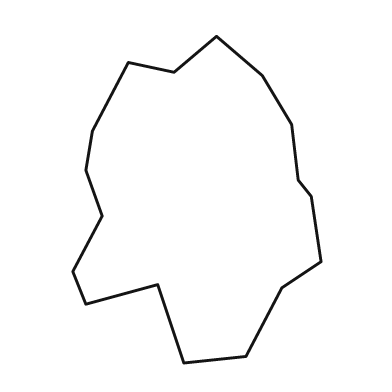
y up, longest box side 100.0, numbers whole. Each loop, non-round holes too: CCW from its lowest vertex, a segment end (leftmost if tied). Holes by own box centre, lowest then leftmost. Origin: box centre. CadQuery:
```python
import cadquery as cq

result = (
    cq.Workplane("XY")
    .moveTo(-4.0, -50.0)
    .lineTo(15.0, -48.0)
    .lineTo(26.0, -27.0)
    .lineTo(38.0, -19.0)
    .lineTo(35.0, 1.0)
    .lineTo(31.0, 6.0)
    .lineTo(29.0, 23.0)
    .lineTo(20.0, 38.0)
    .lineTo(6.0, 50.0)
    .lineTo(-7.0, 39.0)
    .lineTo(-21.0, 42.0)
    .lineTo(-32.0, 21.0)
    .lineTo(-34.0, 9.0)
    .lineTo(-29.0, -5.0)
    .lineTo(-38.0, -22.0)
    .lineTo(-34.0, -32.0)
    .lineTo(-12.0, -26.0)
    .close()
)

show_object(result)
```